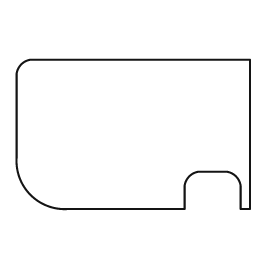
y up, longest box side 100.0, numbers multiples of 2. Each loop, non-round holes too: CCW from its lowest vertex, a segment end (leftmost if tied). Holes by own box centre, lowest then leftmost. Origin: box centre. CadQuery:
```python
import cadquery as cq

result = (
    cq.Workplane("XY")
    .moveTo(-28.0, -32.0)
    .lineTo(22.0, -32.0)
    .lineTo(22.0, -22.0)
    .threePointArc((24.0, -18.0), (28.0, -16.0))
    .lineTo(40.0, -16.0)
    .threePointArc((44.0, -18.0), (46.0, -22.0))
    .lineTo(46.0, -32.0)
    .lineTo(50.0, -32.0)
    .lineTo(50.0, 32.0)
    .lineTo(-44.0, 32.0)
    .threePointArc((-48.0, 30.0), (-50.0, 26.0))
    .lineTo(-50.0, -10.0)
    .threePointArc((-44.0, -26.0), (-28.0, -32.0))
    .close()
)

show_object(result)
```